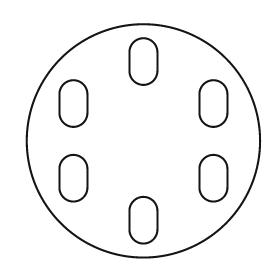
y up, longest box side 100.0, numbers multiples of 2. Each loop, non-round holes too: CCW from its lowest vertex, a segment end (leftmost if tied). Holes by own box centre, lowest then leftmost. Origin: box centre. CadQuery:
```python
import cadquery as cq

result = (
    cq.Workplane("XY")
    .moveTo(0.0, 0.0)
    .circle(50.0)
    .moveTo(-6.0, -38.0)
    .threePointArc((0.0, -44.0), (6.0, -38.0))
    .lineTo(6.0, -30.0)
    .threePointArc((0.0, -24.0), (-6.0, -30.0))
    .close()
    .moveTo(-36.0, -20.0)
    .threePointArc((-30.0, -26.0), (-24.0, -20.0))
    .lineTo(-24.0, -12.0)
    .threePointArc((-30.0, -6.0), (-36.0, -12.0))
    .close()
    .moveTo(24.0, -20.0)
    .threePointArc((30.0, -26.0), (36.0, -20.0))
    .lineTo(36.0, -12.0)
    .threePointArc((30.0, -6.0), (24.0, -12.0))
    .close()
    .moveTo(-36.0, 12.0)
    .threePointArc((-30.0, 6.0), (-24.0, 12.0))
    .lineTo(-24.0, 20.0)
    .threePointArc((-30.0, 26.0), (-36.0, 20.0))
    .close()
    .moveTo(24.0, 12.0)
    .threePointArc((30.0, 6.0), (36.0, 12.0))
    .lineTo(36.0, 20.0)
    .threePointArc((30.0, 26.0), (24.0, 20.0))
    .close()
    .moveTo(-6.0, 30.0)
    .threePointArc((0.0, 24.0), (6.0, 30.0))
    .lineTo(6.0, 38.0)
    .threePointArc((0.0, 44.0), (-6.0, 38.0))
    .close()
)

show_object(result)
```